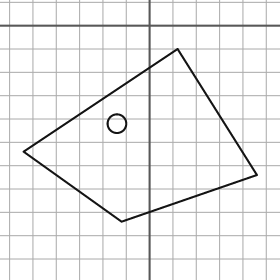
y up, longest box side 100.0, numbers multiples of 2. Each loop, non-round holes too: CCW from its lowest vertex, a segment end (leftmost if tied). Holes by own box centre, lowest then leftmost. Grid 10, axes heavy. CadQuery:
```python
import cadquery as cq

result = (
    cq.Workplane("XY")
    .moveTo(-12.0, -84.0)
    .lineTo(46.0, -64.0)
    .lineTo(12.0, -10.0)
    .lineTo(-54.0, -54.0)
    .close()
    .moveTo(-14.0, -42.0)
    .circle(4.0)
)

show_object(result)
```